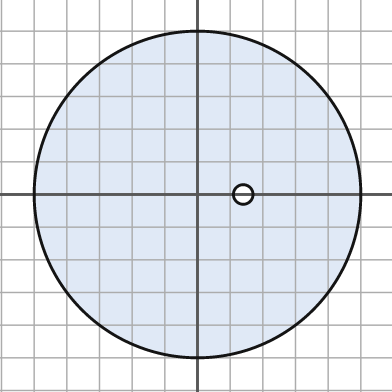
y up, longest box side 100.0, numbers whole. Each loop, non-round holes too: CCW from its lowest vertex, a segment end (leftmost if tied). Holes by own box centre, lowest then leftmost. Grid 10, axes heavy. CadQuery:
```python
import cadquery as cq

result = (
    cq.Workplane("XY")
    .moveTo(0.0, 0.0)
    .circle(50.0)
    .moveTo(14.0, 0.0)
    .circle(3.0)
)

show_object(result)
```